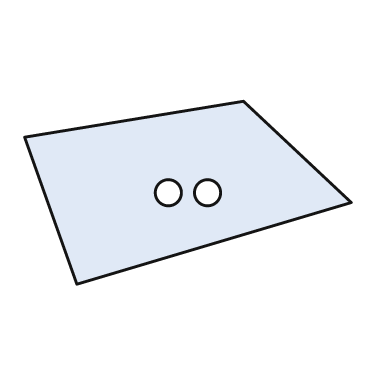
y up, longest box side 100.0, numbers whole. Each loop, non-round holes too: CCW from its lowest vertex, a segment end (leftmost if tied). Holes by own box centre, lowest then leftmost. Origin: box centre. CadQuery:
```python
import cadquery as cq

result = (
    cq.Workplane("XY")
    .moveTo(-34.0, -28.0)
    .lineTo(50.0, -3.0)
    .lineTo(17.0, 28.0)
    .lineTo(-50.0, 17.0)
    .close()
    .moveTo(-6.0, 0.0)
    .circle(4.0)
    .moveTo(6.0, 0.0)
    .circle(4.0)
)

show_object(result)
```